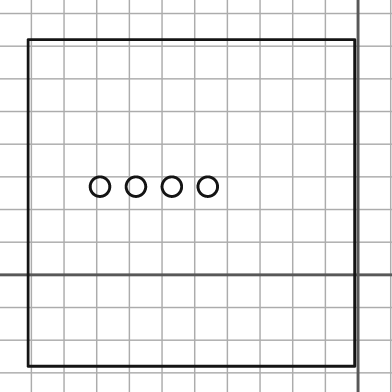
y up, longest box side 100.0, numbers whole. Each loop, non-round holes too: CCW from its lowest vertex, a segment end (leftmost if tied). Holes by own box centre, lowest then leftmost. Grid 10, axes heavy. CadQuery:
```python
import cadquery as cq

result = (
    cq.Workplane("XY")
    .moveTo(-101.0, -28.0)
    .lineTo(-1.0, -28.0)
    .lineTo(-1.0, 72.0)
    .lineTo(-101.0, 72.0)
    .close()
    .moveTo(-79.0, 27.0)
    .circle(3.0)
    .moveTo(-68.0, 27.0)
    .circle(3.0)
    .moveTo(-57.0, 27.0)
    .circle(3.0)
    .moveTo(-46.0, 27.0)
    .circle(3.0)
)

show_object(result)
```